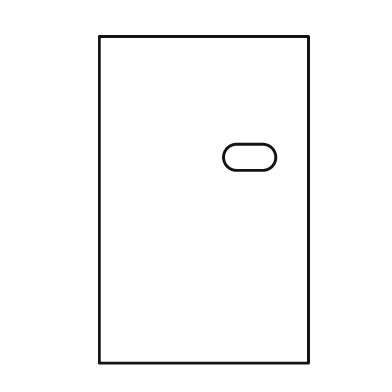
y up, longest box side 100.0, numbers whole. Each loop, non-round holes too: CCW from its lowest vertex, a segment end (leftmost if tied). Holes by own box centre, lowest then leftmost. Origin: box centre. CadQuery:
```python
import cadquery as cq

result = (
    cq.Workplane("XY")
    .moveTo(-32.0, -50.0)
    .lineTo(32.0, -50.0)
    .lineTo(32.0, 50.0)
    .lineTo(-32.0, 50.0)
    .close()
    .moveTo(10.0, 9.0)
    .lineTo(18.0, 9.0)
    .threePointArc((22.0, 13.0), (18.0, 17.0))
    .lineTo(10.0, 17.0)
    .threePointArc((6.0, 13.0), (10.0, 9.0))
    .close()
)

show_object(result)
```